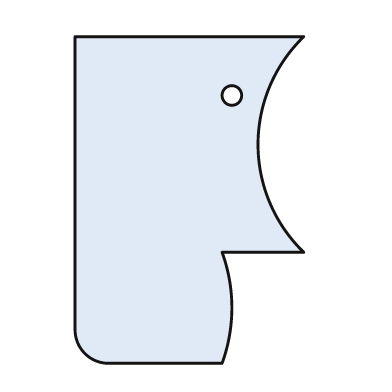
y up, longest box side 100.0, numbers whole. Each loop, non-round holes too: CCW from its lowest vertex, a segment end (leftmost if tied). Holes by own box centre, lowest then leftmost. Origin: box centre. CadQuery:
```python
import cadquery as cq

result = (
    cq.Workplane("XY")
    .moveTo(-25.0, -50.0)
    .lineTo(10.0, -50.0)
    .threePointArc((13.0, -33.0), (10.0, -16.0))
    .lineTo(35.0, -16.0)
    .threePointArc((21.0, 17.0), (35.0, 50.0))
    .lineTo(-35.0, 50.0)
    .lineTo(-35.0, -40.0)
    .threePointArc((-32.0, -47.0), (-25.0, -50.0))
    .close()
    .moveTo(13.0, 32.0)
    .circle(3.0)
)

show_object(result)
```